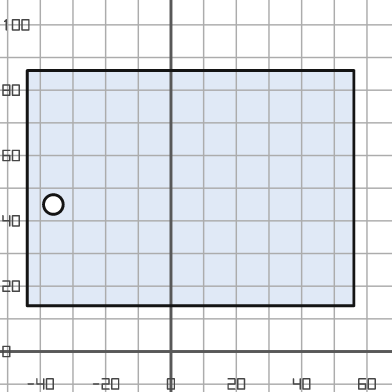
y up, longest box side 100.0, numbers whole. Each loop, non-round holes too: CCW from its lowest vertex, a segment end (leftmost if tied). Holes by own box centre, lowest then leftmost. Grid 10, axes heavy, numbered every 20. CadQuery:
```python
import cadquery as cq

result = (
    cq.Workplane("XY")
    .moveTo(-44.0, 14.0)
    .lineTo(56.0, 14.0)
    .lineTo(56.0, 86.0)
    .lineTo(-44.0, 86.0)
    .close()
    .moveTo(-36.0, 45.0)
    .circle(3.0)
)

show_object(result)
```